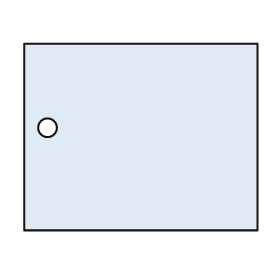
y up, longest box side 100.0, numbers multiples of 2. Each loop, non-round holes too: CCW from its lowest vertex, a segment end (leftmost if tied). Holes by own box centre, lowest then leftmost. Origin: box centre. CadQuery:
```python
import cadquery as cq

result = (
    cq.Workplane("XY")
    .moveTo(-50.0, -40.0)
    .lineTo(50.0, -40.0)
    .lineTo(50.0, 40.0)
    .lineTo(-50.0, 40.0)
    .close()
    .moveTo(-40.0, 4.0)
    .circle(4.0)
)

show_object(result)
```